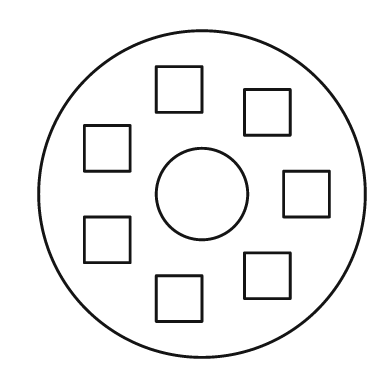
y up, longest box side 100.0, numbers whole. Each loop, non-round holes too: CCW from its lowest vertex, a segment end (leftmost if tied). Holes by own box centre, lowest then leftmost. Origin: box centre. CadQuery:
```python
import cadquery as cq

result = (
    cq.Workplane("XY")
    .moveTo(0.0, 0.0)
    .circle(50.0)
    .moveTo(-14.0, -39.0)
    .lineTo(0.0, -39.0)
    .lineTo(0.0, -25.0)
    .lineTo(-14.0, -25.0)
    .close()
    .moveTo(13.0, -32.0)
    .lineTo(27.0, -32.0)
    .lineTo(27.0, -18.0)
    .lineTo(13.0, -18.0)
    .close()
    .moveTo(-36.0, -21.0)
    .lineTo(-22.0, -21.0)
    .lineTo(-22.0, -7.0)
    .lineTo(-36.0, -7.0)
    .close()
    .moveTo(0.0, 0.0)
    .circle(14.0)
    .moveTo(25.0, -7.0)
    .lineTo(39.0, -7.0)
    .lineTo(39.0, 7.0)
    .lineTo(25.0, 7.0)
    .close()
    .moveTo(-36.0, 7.0)
    .lineTo(-22.0, 7.0)
    .lineTo(-22.0, 21.0)
    .lineTo(-36.0, 21.0)
    .close()
    .moveTo(13.0, 18.0)
    .lineTo(27.0, 18.0)
    .lineTo(27.0, 32.0)
    .lineTo(13.0, 32.0)
    .close()
    .moveTo(-14.0, 25.0)
    .lineTo(0.0, 25.0)
    .lineTo(0.0, 39.0)
    .lineTo(-14.0, 39.0)
    .close()
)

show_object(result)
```